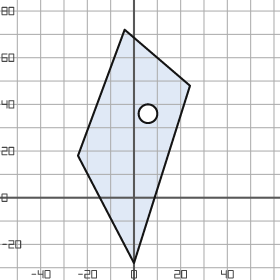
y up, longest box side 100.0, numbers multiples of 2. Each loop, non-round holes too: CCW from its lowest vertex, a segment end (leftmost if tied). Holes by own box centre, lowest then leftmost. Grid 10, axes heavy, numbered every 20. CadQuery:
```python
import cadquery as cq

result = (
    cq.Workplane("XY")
    .moveTo(0.0, -28.0)
    .lineTo(24.0, 48.0)
    .lineTo(-4.0, 72.0)
    .lineTo(-24.0, 18.0)
    .close()
    .moveTo(6.0, 36.0)
    .circle(4.0)
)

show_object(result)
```